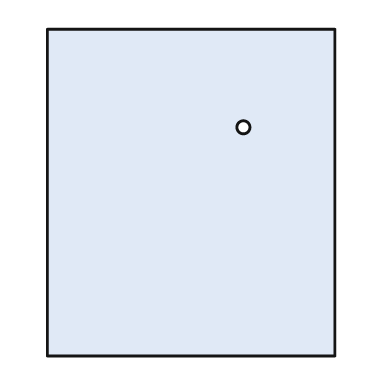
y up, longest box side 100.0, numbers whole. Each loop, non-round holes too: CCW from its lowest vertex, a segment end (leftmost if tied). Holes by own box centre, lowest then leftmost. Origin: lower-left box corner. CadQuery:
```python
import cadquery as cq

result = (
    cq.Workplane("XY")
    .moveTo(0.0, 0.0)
    .lineTo(88.0, 0.0)
    .lineTo(88.0, 100.0)
    .lineTo(0.0, 100.0)
    .close()
    .moveTo(60.0, 70.0)
    .circle(2.0)
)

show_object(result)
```